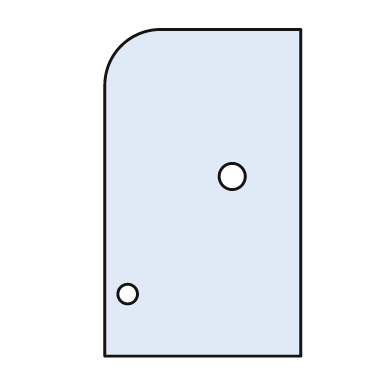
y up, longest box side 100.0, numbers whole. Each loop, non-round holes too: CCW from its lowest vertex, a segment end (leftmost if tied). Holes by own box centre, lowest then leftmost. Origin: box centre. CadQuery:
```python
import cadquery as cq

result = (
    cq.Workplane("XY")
    .moveTo(-30.0, -50.0)
    .lineTo(30.0, -50.0)
    .lineTo(30.0, 50.0)
    .lineTo(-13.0, 50.0)
    .threePointArc((-25.0, 45.0), (-30.0, 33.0))
    .close()
    .moveTo(-23.0, -31.0)
    .circle(3.0)
    .moveTo(9.0, 5.0)
    .circle(4.0)
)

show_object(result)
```